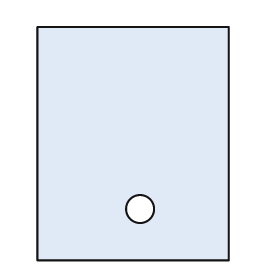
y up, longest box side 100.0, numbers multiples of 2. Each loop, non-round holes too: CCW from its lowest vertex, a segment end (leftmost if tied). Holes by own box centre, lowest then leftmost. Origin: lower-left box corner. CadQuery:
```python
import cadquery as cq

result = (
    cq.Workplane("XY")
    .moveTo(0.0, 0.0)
    .lineTo(82.0, 0.0)
    .lineTo(82.0, 100.0)
    .lineTo(0.0, 100.0)
    .close()
    .moveTo(44.0, 22.0)
    .circle(6.0)
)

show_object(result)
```